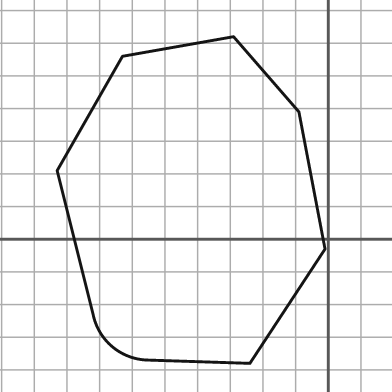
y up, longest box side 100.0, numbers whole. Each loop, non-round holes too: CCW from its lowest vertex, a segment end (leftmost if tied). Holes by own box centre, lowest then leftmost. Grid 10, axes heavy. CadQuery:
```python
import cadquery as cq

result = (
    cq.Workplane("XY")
    .moveTo(-24.0, -38.0)
    .lineTo(-1.0, -3.0)
    .lineTo(-9.0, 39.0)
    .lineTo(-29.0, 62.0)
    .lineTo(-63.0, 56.0)
    .lineTo(-83.0, 21.0)
    .lineTo(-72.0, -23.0)
    .threePointArc((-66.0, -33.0), (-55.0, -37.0))
    .close()
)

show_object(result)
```